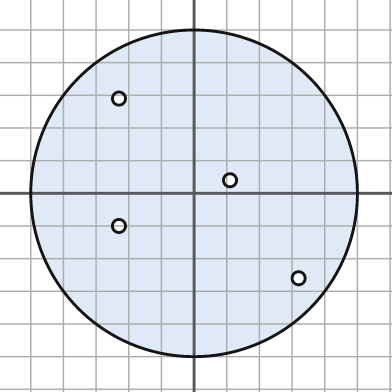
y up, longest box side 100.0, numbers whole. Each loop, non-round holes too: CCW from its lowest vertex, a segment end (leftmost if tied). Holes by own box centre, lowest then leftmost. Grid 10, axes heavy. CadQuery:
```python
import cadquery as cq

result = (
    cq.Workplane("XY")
    .moveTo(0.0, 0.0)
    .circle(50.0)
    .moveTo(32.0, -26.0)
    .circle(2.0)
    .moveTo(-23.0, -10.0)
    .circle(2.0)
    .moveTo(11.0, 4.0)
    .circle(2.0)
    .moveTo(-23.0, 29.0)
    .circle(2.0)
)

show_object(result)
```